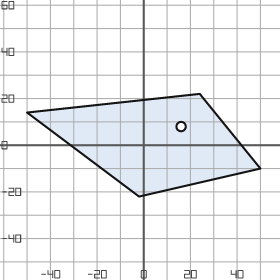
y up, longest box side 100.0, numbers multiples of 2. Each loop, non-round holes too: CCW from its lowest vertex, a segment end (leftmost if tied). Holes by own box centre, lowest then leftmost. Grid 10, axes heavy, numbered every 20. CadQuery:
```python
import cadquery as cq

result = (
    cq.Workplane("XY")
    .moveTo(-2.0, -22.0)
    .lineTo(50.0, -10.0)
    .lineTo(24.0, 22.0)
    .lineTo(-50.0, 14.0)
    .close()
    .moveTo(16.0, 8.0)
    .circle(2.0)
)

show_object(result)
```